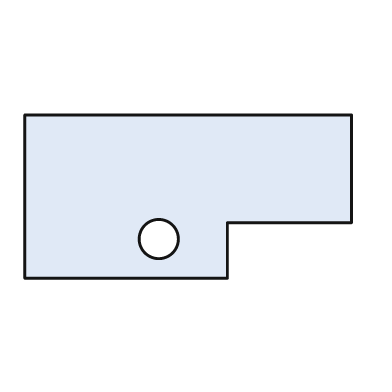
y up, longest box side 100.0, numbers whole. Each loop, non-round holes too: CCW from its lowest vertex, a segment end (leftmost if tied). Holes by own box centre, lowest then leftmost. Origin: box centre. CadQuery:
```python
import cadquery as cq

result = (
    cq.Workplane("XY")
    .moveTo(-50.0, -25.0)
    .lineTo(12.0, -25.0)
    .lineTo(12.0, -8.0)
    .lineTo(50.0, -8.0)
    .lineTo(50.0, 25.0)
    .lineTo(-50.0, 25.0)
    .close()
    .moveTo(-9.0, -13.0)
    .circle(6.0)
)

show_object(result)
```